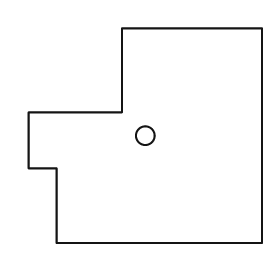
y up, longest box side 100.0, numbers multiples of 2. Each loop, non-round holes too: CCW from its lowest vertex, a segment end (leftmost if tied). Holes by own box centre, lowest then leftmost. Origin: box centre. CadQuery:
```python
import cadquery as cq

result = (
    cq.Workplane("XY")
    .moveTo(-38.0, -46.0)
    .lineTo(50.0, -46.0)
    .lineTo(50.0, 46.0)
    .lineTo(-10.0, 46.0)
    .lineTo(-10.0, 10.0)
    .lineTo(-50.0, 10.0)
    .lineTo(-50.0, -14.0)
    .lineTo(-38.0, -14.0)
    .close()
    .moveTo(0.0, 0.0)
    .circle(4.0)
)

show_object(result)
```